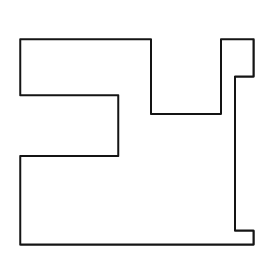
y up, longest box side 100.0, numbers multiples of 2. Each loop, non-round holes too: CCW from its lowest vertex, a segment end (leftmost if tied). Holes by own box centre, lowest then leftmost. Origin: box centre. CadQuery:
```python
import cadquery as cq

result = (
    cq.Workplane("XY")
    .moveTo(-50.0, -44.0)
    .lineTo(50.0, -44.0)
    .lineTo(50.0, -38.0)
    .lineTo(42.0, -38.0)
    .lineTo(42.0, 28.0)
    .lineTo(50.0, 28.0)
    .lineTo(50.0, 44.0)
    .lineTo(36.0, 44.0)
    .lineTo(36.0, 12.0)
    .lineTo(6.0, 12.0)
    .lineTo(6.0, 44.0)
    .lineTo(-50.0, 44.0)
    .lineTo(-50.0, 20.0)
    .lineTo(-8.0, 20.0)
    .lineTo(-8.0, -6.0)
    .lineTo(-50.0, -6.0)
    .close()
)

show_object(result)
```